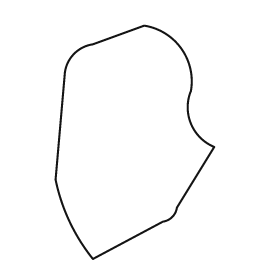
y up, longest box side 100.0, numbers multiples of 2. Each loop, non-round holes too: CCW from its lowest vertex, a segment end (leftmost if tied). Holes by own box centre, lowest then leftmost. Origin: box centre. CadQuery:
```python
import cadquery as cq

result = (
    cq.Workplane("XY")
    .moveTo(-18.0, -50.0)
    .lineTo(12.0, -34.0)
    .threePointArc((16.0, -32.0), (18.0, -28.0))
    .lineTo(34.0, -2.0)
    .threePointArc((24.0, 8.0), (24.0, 22.0))
    .threePointArc((20.0, 40.0), (4.0, 50.0))
    .lineTo(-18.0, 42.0)
    .threePointArc((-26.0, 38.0), (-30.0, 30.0))
    .lineTo(-34.0, -16.0)
    .threePointArc((-28.0, -34.0), (-18.0, -50.0))
    .close()
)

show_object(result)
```